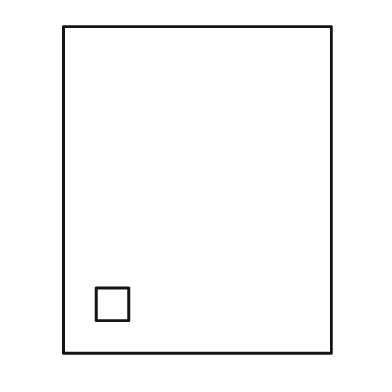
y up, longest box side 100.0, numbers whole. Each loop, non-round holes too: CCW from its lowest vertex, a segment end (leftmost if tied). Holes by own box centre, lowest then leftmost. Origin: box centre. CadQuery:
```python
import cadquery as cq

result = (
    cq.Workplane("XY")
    .moveTo(-41.0, -50.0)
    .lineTo(41.0, -50.0)
    .lineTo(41.0, 50.0)
    .lineTo(-41.0, 50.0)
    .close()
    .moveTo(-31.0, -40.0)
    .lineTo(-21.0, -40.0)
    .lineTo(-21.0, -30.0)
    .lineTo(-31.0, -30.0)
    .close()
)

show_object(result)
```